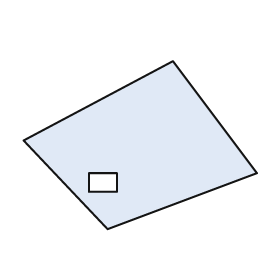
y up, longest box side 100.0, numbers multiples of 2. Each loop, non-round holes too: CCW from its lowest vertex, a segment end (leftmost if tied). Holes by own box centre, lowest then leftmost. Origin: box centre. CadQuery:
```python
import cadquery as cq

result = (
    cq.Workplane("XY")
    .moveTo(-14.0, -36.0)
    .lineTo(50.0, -12.0)
    .lineTo(14.0, 36.0)
    .lineTo(-50.0, 2.0)
    .close()
    .moveTo(-22.0, -20.0)
    .lineTo(-10.0, -20.0)
    .lineTo(-10.0, -12.0)
    .lineTo(-22.0, -12.0)
    .close()
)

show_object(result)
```